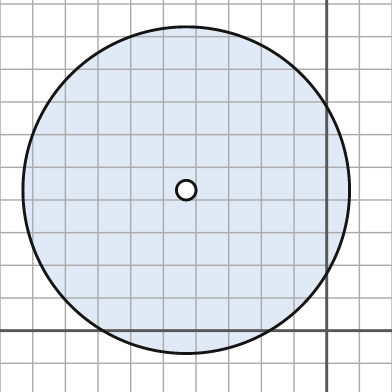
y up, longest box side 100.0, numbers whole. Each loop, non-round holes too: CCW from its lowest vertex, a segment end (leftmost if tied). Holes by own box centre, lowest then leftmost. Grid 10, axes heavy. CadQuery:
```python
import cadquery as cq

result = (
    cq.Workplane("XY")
    .moveTo(-43.0, 43.0)
    .circle(50.0)
    .moveTo(-43.0, 43.0)
    .circle(3.0)
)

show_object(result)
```